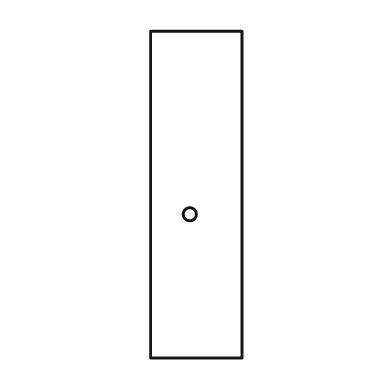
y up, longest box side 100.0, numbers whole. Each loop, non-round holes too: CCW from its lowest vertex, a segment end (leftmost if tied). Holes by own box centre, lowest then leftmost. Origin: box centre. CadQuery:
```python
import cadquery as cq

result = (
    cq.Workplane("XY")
    .moveTo(-14.0, -50.0)
    .lineTo(14.0, -50.0)
    .lineTo(14.0, 50.0)
    .lineTo(-14.0, 50.0)
    .close()
    .moveTo(-2.0, -6.0)
    .circle(2.0)
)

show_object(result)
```